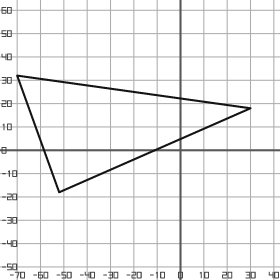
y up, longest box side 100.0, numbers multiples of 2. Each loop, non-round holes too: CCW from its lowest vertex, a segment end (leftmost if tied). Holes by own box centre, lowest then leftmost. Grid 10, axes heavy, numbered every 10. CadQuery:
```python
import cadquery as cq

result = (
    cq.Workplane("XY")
    .moveTo(-52.0, -18.0)
    .lineTo(30.0, 18.0)
    .lineTo(-70.0, 32.0)
    .close()
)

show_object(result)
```